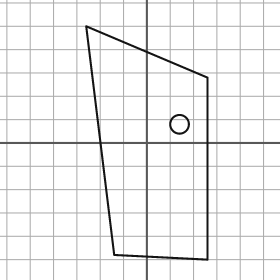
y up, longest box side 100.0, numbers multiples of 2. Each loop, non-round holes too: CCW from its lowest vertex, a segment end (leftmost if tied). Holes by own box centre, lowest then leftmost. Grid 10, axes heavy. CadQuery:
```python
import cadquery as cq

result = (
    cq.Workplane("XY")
    .moveTo(26.0, -50.0)
    .lineTo(26.0, 28.0)
    .lineTo(-26.0, 50.0)
    .lineTo(-14.0, -48.0)
    .close()
    .moveTo(14.0, 8.0)
    .circle(4.0)
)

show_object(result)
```